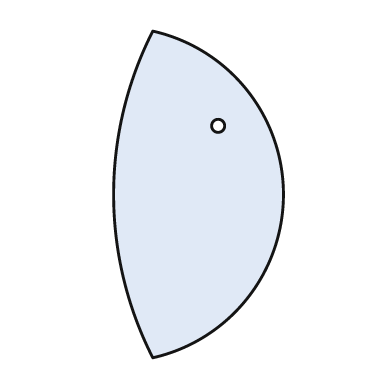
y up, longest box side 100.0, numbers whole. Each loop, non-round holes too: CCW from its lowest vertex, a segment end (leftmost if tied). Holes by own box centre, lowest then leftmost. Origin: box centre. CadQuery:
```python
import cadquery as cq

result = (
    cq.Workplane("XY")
    .moveTo(-14.0, -50.0)
    .threePointArc((26.0, 0.0), (-14.0, 50.0))
    .threePointArc((-26.0, 0.0), (-14.0, -50.0))
    .close()
    .moveTo(6.0, 21.0)
    .circle(2.0)
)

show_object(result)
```